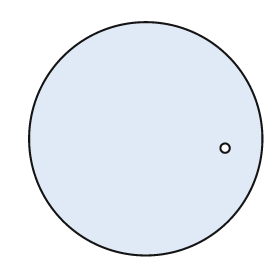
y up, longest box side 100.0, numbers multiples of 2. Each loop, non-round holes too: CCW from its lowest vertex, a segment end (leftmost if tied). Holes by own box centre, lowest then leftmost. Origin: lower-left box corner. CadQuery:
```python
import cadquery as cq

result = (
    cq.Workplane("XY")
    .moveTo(50.0, 50.0)
    .circle(50.0)
    .moveTo(84.0, 46.0)
    .circle(2.0)
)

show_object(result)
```